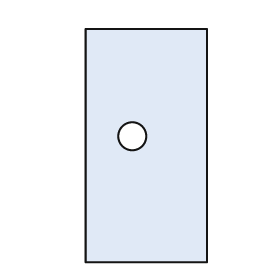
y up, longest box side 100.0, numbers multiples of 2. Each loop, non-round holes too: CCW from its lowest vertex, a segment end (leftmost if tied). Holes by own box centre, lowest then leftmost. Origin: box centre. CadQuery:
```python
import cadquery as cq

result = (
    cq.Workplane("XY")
    .moveTo(-26.0, -50.0)
    .lineTo(26.0, -50.0)
    .lineTo(26.0, 50.0)
    .lineTo(-26.0, 50.0)
    .close()
    .moveTo(-6.0, 4.0)
    .circle(6.0)
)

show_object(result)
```